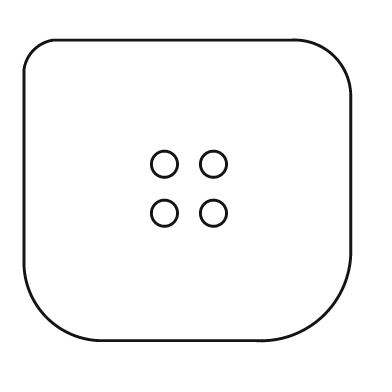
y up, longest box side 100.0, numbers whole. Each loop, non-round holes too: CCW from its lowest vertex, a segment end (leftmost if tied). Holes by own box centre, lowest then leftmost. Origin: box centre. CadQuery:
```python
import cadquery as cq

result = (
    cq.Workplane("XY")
    .moveTo(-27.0, -46.0)
    .lineTo(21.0, -46.0)
    .threePointArc((42.0, -38.0), (50.0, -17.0))
    .lineTo(50.0, 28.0)
    .threePointArc((45.0, 41.0), (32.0, 46.0))
    .lineTo(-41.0, 46.0)
    .threePointArc((-47.0, 43.0), (-50.0, 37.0))
    .lineTo(-50.0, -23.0)
    .threePointArc((-43.0, -39.0), (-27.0, -46.0))
    .close()
    .moveTo(-7.0, -7.0)
    .circle(4.0)
    .moveTo(8.0, -7.0)
    .circle(4.0)
    .moveTo(-7.0, 8.0)
    .circle(4.0)
    .moveTo(8.0, 8.0)
    .circle(4.0)
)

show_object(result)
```